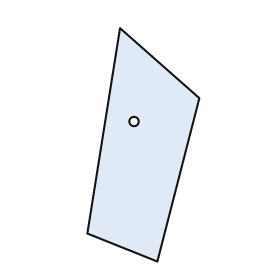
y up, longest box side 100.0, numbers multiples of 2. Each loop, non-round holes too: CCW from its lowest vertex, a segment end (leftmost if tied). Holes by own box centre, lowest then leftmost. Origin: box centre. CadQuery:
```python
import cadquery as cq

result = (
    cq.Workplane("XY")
    .moveTo(6.0, -50.0)
    .lineTo(24.0, 20.0)
    .lineTo(-10.0, 50.0)
    .lineTo(-24.0, -38.0)
    .close()
    .moveTo(-4.0, 10.0)
    .circle(2.0)
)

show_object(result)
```